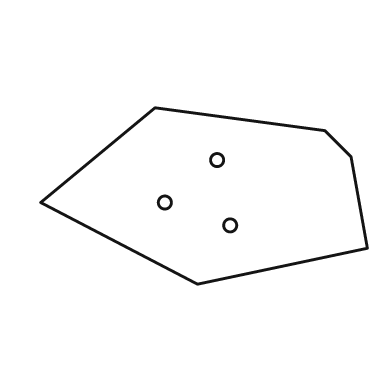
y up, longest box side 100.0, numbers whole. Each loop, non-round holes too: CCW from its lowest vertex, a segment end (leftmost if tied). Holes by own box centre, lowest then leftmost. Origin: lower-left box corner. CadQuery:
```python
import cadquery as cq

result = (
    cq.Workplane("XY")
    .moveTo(48.0, 0.0)
    .lineTo(100.0, 11.0)
    .lineTo(95.0, 39.0)
    .lineTo(87.0, 47.0)
    .lineTo(35.0, 54.0)
    .lineTo(0.0, 25.0)
    .close()
    .moveTo(58.0, 18.0)
    .circle(2.0)
    .moveTo(38.0, 25.0)
    .circle(2.0)
    .moveTo(54.0, 38.0)
    .circle(2.0)
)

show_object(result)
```